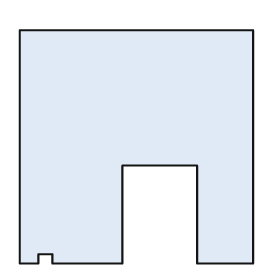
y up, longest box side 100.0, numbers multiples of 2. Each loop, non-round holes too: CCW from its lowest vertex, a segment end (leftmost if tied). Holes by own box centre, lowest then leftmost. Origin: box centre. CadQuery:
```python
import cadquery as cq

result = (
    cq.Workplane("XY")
    .moveTo(-50.0, -50.0)
    .lineTo(-42.0, -50.0)
    .lineTo(-42.0, -46.0)
    .lineTo(-36.0, -46.0)
    .lineTo(-36.0, -50.0)
    .lineTo(-6.0, -50.0)
    .lineTo(-6.0, -8.0)
    .lineTo(26.0, -8.0)
    .lineTo(26.0, -50.0)
    .lineTo(50.0, -50.0)
    .lineTo(50.0, 50.0)
    .lineTo(-50.0, 50.0)
    .close()
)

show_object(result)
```